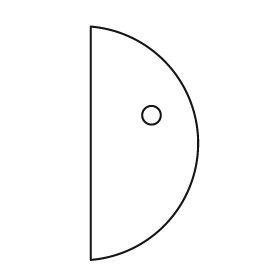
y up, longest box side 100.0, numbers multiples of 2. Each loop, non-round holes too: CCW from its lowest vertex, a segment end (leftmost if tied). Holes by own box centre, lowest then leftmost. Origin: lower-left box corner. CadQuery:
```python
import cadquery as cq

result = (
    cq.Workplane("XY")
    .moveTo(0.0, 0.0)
    .threePointArc((46.0, 50.0), (0.0, 100.0))
    .close()
    .moveTo(26.0, 62.0)
    .circle(4.0)
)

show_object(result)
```